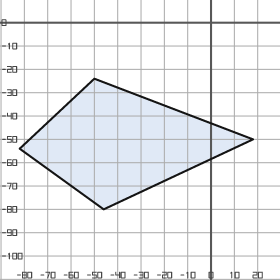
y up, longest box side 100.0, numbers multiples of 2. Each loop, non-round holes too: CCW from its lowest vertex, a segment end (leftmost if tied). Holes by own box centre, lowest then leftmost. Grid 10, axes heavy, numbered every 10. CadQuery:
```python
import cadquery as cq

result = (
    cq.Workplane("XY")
    .moveTo(-46.0, -80.0)
    .lineTo(18.0, -50.0)
    .lineTo(-50.0, -24.0)
    .lineTo(-82.0, -54.0)
    .close()
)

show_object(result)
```